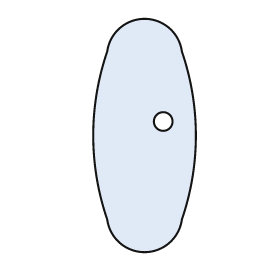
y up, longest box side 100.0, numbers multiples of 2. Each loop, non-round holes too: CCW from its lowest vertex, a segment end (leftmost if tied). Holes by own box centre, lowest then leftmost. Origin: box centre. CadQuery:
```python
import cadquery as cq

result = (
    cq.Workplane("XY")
    .moveTo(-16.0, -36.0)
    .threePointArc((0.0, -50.0), (16.0, -36.0))
    .threePointArc((22.0, 0.0), (16.0, 36.0))
    .threePointArc((0.0, 50.0), (-16.0, 36.0))
    .threePointArc((-22.0, 0.0), (-16.0, -36.0))
    .close()
    .moveTo(8.0, 6.0)
    .circle(4.0)
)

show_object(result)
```